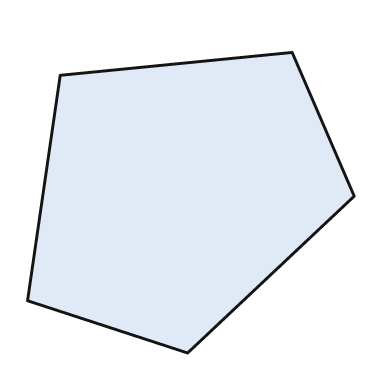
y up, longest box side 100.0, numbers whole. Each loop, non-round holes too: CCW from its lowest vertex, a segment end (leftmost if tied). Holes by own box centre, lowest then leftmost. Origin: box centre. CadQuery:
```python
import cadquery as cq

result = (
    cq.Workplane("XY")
    .moveTo(-1.0, -46.0)
    .lineTo(50.0, 2.0)
    .lineTo(31.0, 46.0)
    .lineTo(-40.0, 39.0)
    .lineTo(-50.0, -30.0)
    .close()
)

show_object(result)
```